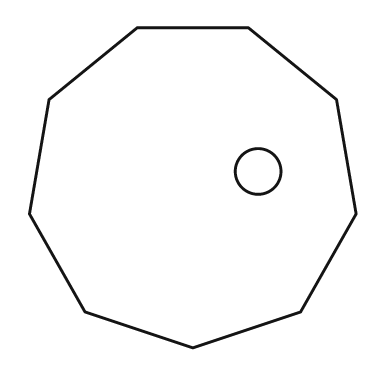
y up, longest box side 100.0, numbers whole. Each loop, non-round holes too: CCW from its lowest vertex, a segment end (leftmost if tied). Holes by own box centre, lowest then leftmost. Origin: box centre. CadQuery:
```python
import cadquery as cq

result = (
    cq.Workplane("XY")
    .moveTo(0.0, -49.0)
    .lineTo(33.0, -38.0)
    .lineTo(50.0, -8.0)
    .lineTo(44.0, 27.0)
    .lineTo(17.0, 49.0)
    .lineTo(-17.0, 49.0)
    .lineTo(-44.0, 27.0)
    .lineTo(-50.0, -8.0)
    .lineTo(-33.0, -38.0)
    .close()
    .moveTo(20.0, 5.0)
    .circle(7.0)
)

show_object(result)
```